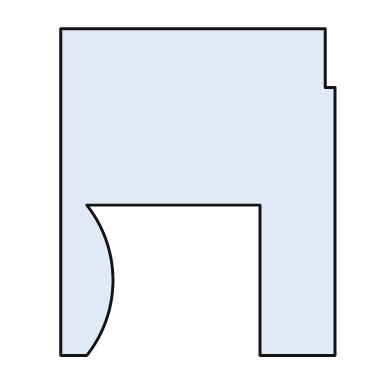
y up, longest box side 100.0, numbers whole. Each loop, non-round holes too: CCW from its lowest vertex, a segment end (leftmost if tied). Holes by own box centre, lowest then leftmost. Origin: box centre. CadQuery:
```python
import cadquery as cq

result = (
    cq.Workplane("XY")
    .moveTo(-42.0, -50.0)
    .lineTo(-34.0, -50.0)
    .threePointArc((-26.0, -27.0), (-34.0, -4.0))
    .lineTo(19.0, -4.0)
    .lineTo(19.0, -50.0)
    .lineTo(42.0, -50.0)
    .lineTo(42.0, 32.0)
    .lineTo(39.0, 32.0)
    .lineTo(39.0, 50.0)
    .lineTo(-42.0, 50.0)
    .close()
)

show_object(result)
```